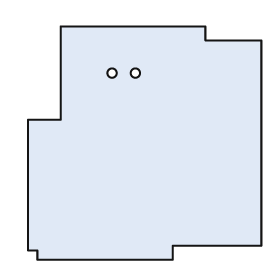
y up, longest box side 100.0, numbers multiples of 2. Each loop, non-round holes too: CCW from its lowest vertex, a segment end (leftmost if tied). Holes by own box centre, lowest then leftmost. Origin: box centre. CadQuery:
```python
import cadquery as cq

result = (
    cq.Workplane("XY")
    .moveTo(-46.0, -50.0)
    .lineTo(12.0, -50.0)
    .lineTo(12.0, -44.0)
    .lineTo(50.0, -44.0)
    .lineTo(50.0, 44.0)
    .lineTo(26.0, 44.0)
    .lineTo(26.0, 50.0)
    .lineTo(-36.0, 50.0)
    .lineTo(-36.0, 10.0)
    .lineTo(-50.0, 10.0)
    .lineTo(-50.0, -46.0)
    .lineTo(-46.0, -46.0)
    .close()
    .moveTo(-14.0, 30.0)
    .circle(2.0)
    .moveTo(-4.0, 30.0)
    .circle(2.0)
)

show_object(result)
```